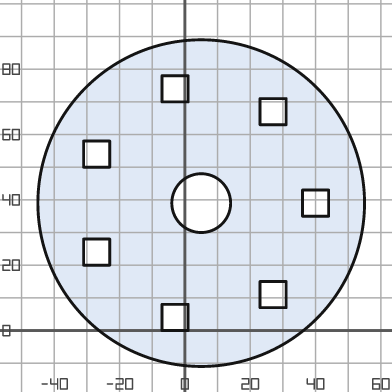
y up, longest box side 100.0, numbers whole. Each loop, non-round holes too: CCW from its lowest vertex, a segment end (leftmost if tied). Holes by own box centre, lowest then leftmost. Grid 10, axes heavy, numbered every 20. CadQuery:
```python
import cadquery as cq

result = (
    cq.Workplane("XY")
    .moveTo(5.0, 39.0)
    .circle(50.0)
    .moveTo(-7.0, 0.0)
    .lineTo(1.0, 0.0)
    .lineTo(1.0, 8.0)
    .lineTo(-7.0, 8.0)
    .close()
    .moveTo(23.0, 7.0)
    .lineTo(31.0, 7.0)
    .lineTo(31.0, 15.0)
    .lineTo(23.0, 15.0)
    .close()
    .moveTo(-31.0, 20.0)
    .lineTo(-23.0, 20.0)
    .lineTo(-23.0, 28.0)
    .lineTo(-31.0, 28.0)
    .close()
    .moveTo(5.0, 39.0)
    .circle(9.0)
    .moveTo(36.0, 35.0)
    .lineTo(44.0, 35.0)
    .lineTo(44.0, 43.0)
    .lineTo(36.0, 43.0)
    .close()
    .moveTo(-31.0, 50.0)
    .lineTo(-23.0, 50.0)
    .lineTo(-23.0, 58.0)
    .lineTo(-31.0, 58.0)
    .close()
    .moveTo(23.0, 63.0)
    .lineTo(31.0, 63.0)
    .lineTo(31.0, 71.0)
    .lineTo(23.0, 71.0)
    .close()
    .moveTo(-7.0, 70.0)
    .lineTo(1.0, 70.0)
    .lineTo(1.0, 78.0)
    .lineTo(-7.0, 78.0)
    .close()
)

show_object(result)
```